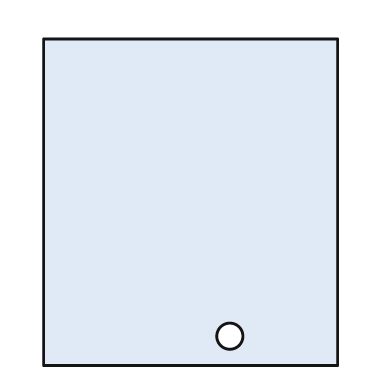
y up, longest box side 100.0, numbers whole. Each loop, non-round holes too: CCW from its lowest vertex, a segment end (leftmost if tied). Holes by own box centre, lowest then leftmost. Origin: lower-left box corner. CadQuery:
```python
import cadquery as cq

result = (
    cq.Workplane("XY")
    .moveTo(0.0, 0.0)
    .lineTo(90.0, 0.0)
    .lineTo(90.0, 100.0)
    .lineTo(0.0, 100.0)
    .close()
    .moveTo(57.0, 9.0)
    .circle(4.0)
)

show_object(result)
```